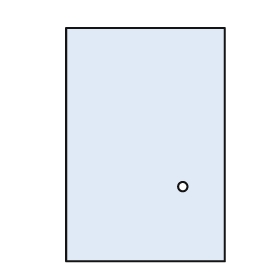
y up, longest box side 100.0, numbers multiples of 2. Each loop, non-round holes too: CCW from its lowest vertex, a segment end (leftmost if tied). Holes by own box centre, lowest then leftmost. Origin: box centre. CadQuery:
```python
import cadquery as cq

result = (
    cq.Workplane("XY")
    .moveTo(-34.0, -50.0)
    .lineTo(34.0, -50.0)
    .lineTo(34.0, 50.0)
    .lineTo(-34.0, 50.0)
    .close()
    .moveTo(16.0, -18.0)
    .circle(2.0)
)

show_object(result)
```